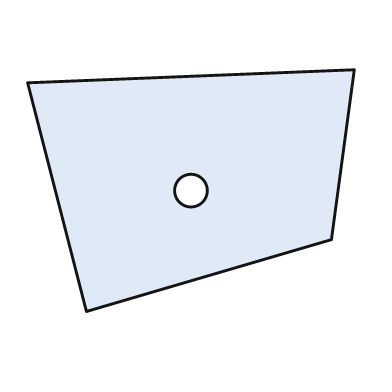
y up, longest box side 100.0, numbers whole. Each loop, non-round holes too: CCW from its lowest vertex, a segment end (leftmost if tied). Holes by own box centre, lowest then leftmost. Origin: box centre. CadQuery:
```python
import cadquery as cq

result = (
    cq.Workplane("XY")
    .moveTo(-32.0, -37.0)
    .lineTo(43.0, -15.0)
    .lineTo(50.0, 37.0)
    .lineTo(-50.0, 33.0)
    .close()
    .moveTo(0.0, 0.0)
    .circle(5.0)
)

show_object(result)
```